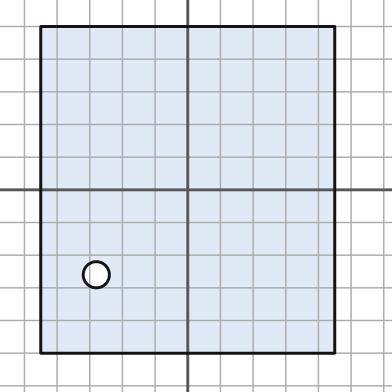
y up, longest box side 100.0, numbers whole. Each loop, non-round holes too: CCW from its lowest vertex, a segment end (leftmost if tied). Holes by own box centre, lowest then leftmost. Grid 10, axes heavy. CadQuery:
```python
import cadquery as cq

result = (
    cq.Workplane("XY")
    .moveTo(-45.0, -50.0)
    .lineTo(45.0, -50.0)
    .lineTo(45.0, 50.0)
    .lineTo(-45.0, 50.0)
    .close()
    .moveTo(-28.0, -26.0)
    .circle(4.0)
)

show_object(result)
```